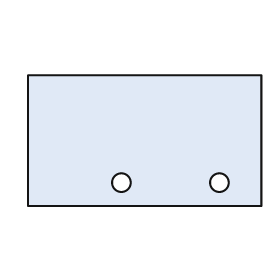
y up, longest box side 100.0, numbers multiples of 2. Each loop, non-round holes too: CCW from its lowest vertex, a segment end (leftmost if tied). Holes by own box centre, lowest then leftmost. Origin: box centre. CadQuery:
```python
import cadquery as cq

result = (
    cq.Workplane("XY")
    .moveTo(-50.0, -28.0)
    .lineTo(50.0, -28.0)
    .lineTo(50.0, 28.0)
    .lineTo(-50.0, 28.0)
    .close()
    .moveTo(-10.0, -18.0)
    .circle(4.0)
    .moveTo(32.0, -18.0)
    .circle(4.0)
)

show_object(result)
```